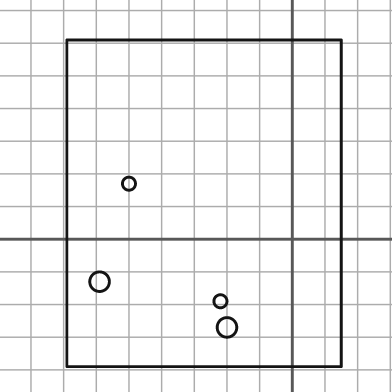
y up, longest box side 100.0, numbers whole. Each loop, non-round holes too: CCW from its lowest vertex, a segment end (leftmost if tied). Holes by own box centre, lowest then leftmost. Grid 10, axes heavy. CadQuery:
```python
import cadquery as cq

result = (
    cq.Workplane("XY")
    .moveTo(-69.0, -39.0)
    .lineTo(15.0, -39.0)
    .lineTo(15.0, 61.0)
    .lineTo(-69.0, 61.0)
    .close()
    .moveTo(-20.0, -27.0)
    .circle(3.0)
    .moveTo(-22.0, -19.0)
    .circle(2.0)
    .moveTo(-59.0, -13.0)
    .circle(3.0)
    .moveTo(-50.0, 17.0)
    .circle(2.0)
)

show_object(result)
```